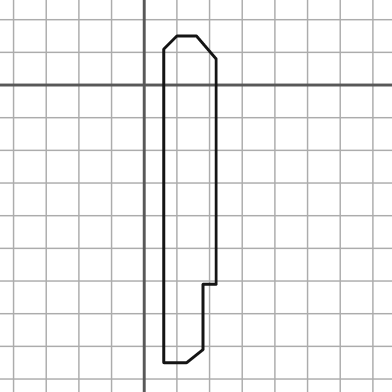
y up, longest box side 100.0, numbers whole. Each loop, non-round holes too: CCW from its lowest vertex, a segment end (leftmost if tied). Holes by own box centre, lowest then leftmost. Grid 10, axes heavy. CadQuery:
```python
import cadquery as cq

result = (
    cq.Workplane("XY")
    .moveTo(6.0, -85.0)
    .lineTo(13.0, -85.0)
    .lineTo(18.0, -81.0)
    .lineTo(18.0, -61.0)
    .lineTo(22.0, -61.0)
    .lineTo(22.0, 8.0)
    .lineTo(16.0, 15.0)
    .lineTo(10.0, 15.0)
    .lineTo(6.0, 11.0)
    .close()
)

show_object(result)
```